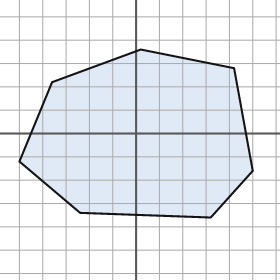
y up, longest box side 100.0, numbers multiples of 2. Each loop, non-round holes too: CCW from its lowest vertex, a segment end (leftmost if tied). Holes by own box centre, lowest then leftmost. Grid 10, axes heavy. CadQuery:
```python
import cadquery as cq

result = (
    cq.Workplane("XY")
    .moveTo(32.0, -36.0)
    .lineTo(50.0, -16.0)
    .lineTo(42.0, 28.0)
    .lineTo(2.0, 36.0)
    .lineTo(-36.0, 22.0)
    .lineTo(-50.0, -12.0)
    .lineTo(-24.0, -34.0)
    .close()
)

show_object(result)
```